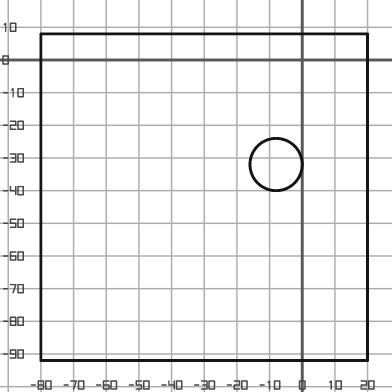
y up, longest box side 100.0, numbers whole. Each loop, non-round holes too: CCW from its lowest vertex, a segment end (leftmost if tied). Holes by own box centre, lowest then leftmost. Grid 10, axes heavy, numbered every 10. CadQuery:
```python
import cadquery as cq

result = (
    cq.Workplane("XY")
    .moveTo(-80.0, -92.0)
    .lineTo(20.0, -92.0)
    .lineTo(20.0, 8.0)
    .lineTo(-80.0, 8.0)
    .close()
    .moveTo(-8.0, -32.0)
    .circle(8.0)
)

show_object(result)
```